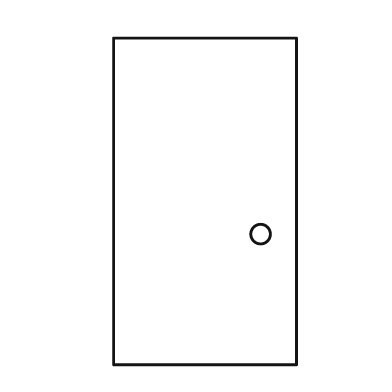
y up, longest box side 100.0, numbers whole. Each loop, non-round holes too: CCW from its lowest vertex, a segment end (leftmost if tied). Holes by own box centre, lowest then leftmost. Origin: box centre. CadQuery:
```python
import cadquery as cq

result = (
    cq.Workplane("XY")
    .moveTo(-28.0, -50.0)
    .lineTo(28.0, -50.0)
    .lineTo(28.0, 50.0)
    .lineTo(-28.0, 50.0)
    .close()
    .moveTo(17.0, -10.0)
    .circle(3.0)
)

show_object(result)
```